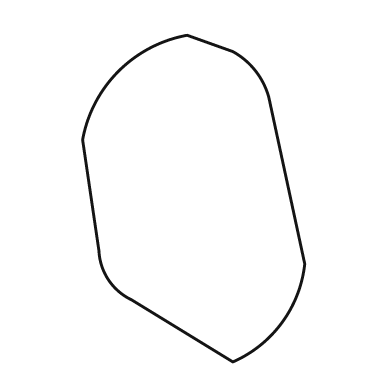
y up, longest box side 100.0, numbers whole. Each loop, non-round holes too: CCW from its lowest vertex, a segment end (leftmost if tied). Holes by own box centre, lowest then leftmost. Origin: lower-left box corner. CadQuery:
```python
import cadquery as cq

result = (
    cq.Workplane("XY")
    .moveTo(46.0, 0.0)
    .threePointArc((61.0, 12.0), (68.0, 30.0))
    .lineTo(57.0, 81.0)
    .threePointArc((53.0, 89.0), (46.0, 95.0))
    .lineTo(32.0, 100.0)
    .threePointArc((11.0, 89.0), (0.0, 68.0))
    .lineTo(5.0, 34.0)
    .threePointArc((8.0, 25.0), (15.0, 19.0))
    .close()
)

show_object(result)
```